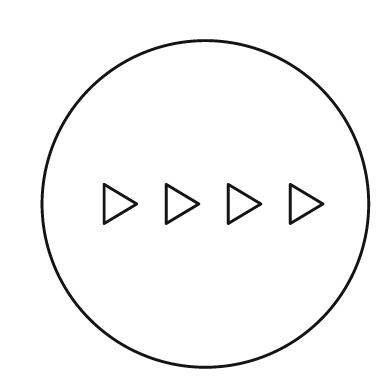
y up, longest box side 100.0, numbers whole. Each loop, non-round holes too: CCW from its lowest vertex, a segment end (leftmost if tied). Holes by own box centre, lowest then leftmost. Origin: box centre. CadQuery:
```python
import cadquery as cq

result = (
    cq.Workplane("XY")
    .moveTo(0.0, 0.0)
    .circle(50.0)
    .moveTo(-31.0, -6.0)
    .lineTo(-21.0, 0.0)
    .lineTo(-31.0, 6.0)
    .close()
    .moveTo(-12.0, -6.0)
    .lineTo(-2.0, 0.0)
    .lineTo(-12.0, 6.0)
    .close()
    .moveTo(7.0, -6.0)
    .lineTo(17.0, 0.0)
    .lineTo(7.0, 6.0)
    .close()
    .moveTo(26.0, -6.0)
    .lineTo(36.0, 0.0)
    .lineTo(26.0, 6.0)
    .close()
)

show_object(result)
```